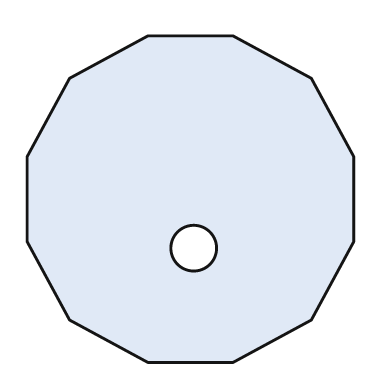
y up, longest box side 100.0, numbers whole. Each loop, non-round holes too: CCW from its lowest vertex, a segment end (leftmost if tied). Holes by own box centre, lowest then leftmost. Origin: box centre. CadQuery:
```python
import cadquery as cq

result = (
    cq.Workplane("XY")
    .moveTo(-13.0, -50.0)
    .lineTo(13.0, -50.0)
    .lineTo(37.0, -37.0)
    .lineTo(50.0, -13.0)
    .lineTo(50.0, 13.0)
    .lineTo(37.0, 37.0)
    .lineTo(13.0, 50.0)
    .lineTo(-13.0, 50.0)
    .lineTo(-37.0, 37.0)
    .lineTo(-50.0, 13.0)
    .lineTo(-50.0, -13.0)
    .lineTo(-37.0, -37.0)
    .close()
    .moveTo(1.0, -15.0)
    .circle(7.0)
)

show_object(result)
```